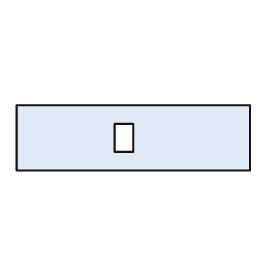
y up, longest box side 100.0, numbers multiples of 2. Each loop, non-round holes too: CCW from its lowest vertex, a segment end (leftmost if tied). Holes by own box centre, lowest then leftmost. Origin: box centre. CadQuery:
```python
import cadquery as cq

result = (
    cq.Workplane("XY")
    .moveTo(-50.0, -14.0)
    .lineTo(50.0, -14.0)
    .lineTo(50.0, 14.0)
    .lineTo(-50.0, 14.0)
    .close()
    .moveTo(-8.0, -6.0)
    .lineTo(0.0, -6.0)
    .lineTo(0.0, 6.0)
    .lineTo(-8.0, 6.0)
    .close()
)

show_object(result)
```